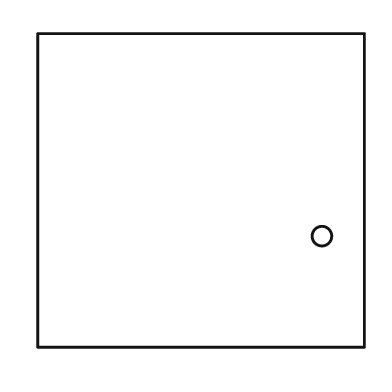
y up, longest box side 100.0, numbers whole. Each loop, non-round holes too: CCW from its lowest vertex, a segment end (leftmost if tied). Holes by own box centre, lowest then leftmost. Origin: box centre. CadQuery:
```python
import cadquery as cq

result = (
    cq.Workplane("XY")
    .moveTo(-50.0, -48.0)
    .lineTo(50.0, -48.0)
    .lineTo(50.0, 48.0)
    .lineTo(-50.0, 48.0)
    .close()
    .moveTo(37.0, -14.0)
    .circle(3.0)
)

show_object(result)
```